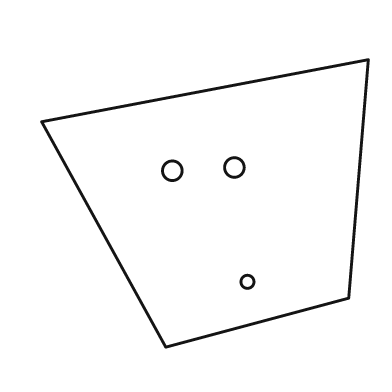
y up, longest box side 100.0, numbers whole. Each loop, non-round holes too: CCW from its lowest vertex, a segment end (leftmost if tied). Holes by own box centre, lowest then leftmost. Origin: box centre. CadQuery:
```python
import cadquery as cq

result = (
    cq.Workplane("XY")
    .moveTo(-12.0, -44.0)
    .lineTo(44.0, -29.0)
    .lineTo(50.0, 44.0)
    .lineTo(-50.0, 25.0)
    .close()
    .moveTo(13.0, -24.0)
    .circle(2.0)
    .moveTo(-10.0, 10.0)
    .circle(3.0)
    .moveTo(9.0, 11.0)
    .circle(3.0)
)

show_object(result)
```